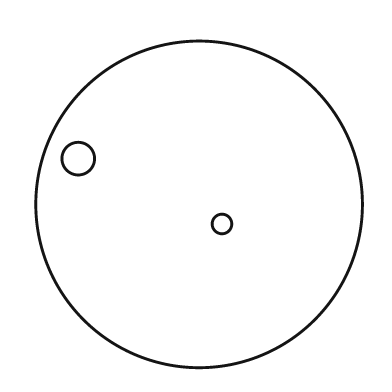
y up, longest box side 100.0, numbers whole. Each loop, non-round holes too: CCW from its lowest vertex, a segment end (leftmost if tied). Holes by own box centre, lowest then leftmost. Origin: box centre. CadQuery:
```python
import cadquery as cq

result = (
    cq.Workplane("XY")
    .moveTo(0.0, 0.0)
    .circle(50.0)
    .moveTo(7.0, -6.0)
    .circle(3.0)
    .moveTo(-37.0, 14.0)
    .circle(5.0)
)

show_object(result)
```